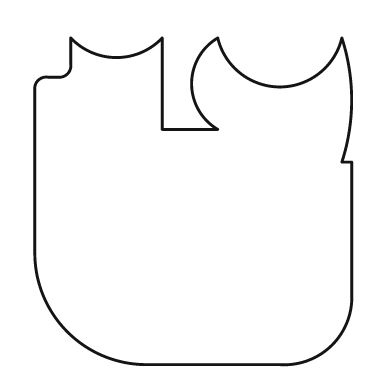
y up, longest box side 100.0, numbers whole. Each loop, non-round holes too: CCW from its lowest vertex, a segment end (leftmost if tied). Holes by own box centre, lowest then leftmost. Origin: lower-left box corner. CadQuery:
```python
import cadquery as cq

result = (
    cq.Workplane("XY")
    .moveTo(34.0, 0.0)
    .lineTo(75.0, 0.0)
    .threePointArc((91.0, 6.0), (97.0, 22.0))
    .lineTo(97.0, 62.0)
    .lineTo(94.0, 62.0)
    .threePointArc((97.0, 81.0), (94.0, 100.0))
    .threePointArc((75.0, 85.0), (56.0, 100.0))
    .threePointArc((48.0, 86.0), (56.0, 72.0))
    .lineTo(39.0, 72.0)
    .lineTo(39.0, 100.0)
    .threePointArc((25.0, 94.0), (11.0, 100.0))
    .lineTo(11.0, 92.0)
    .threePointArc((10.0, 89.0), (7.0, 88.0))
    .lineTo(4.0, 88.0)
    .threePointArc((1.0, 87.0), (0.0, 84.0))
    .lineTo(0.0, 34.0)
    .threePointArc((10.0, 10.0), (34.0, 0.0))
    .close()
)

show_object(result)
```